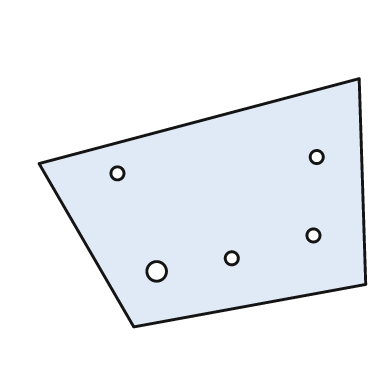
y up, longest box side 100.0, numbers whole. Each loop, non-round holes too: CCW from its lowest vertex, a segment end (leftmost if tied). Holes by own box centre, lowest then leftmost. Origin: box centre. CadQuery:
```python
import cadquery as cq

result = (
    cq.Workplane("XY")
    .moveTo(-21.0, -38.0)
    .lineTo(50.0, -25.0)
    .lineTo(48.0, 38.0)
    .lineTo(-50.0, 12.0)
    .close()
    .moveTo(-14.0, -21.0)
    .circle(3.0)
    .moveTo(9.0, -17.0)
    .circle(2.0)
    .moveTo(34.0, -10.0)
    .circle(2.0)
    .moveTo(-26.0, 9.0)
    .circle(2.0)
    .moveTo(35.0, 14.0)
    .circle(2.0)
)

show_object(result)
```